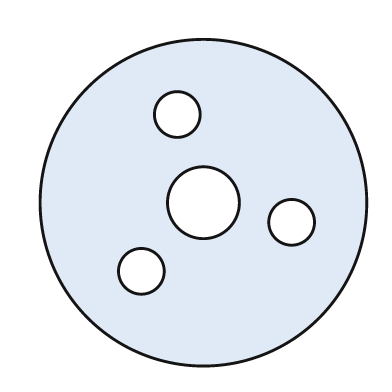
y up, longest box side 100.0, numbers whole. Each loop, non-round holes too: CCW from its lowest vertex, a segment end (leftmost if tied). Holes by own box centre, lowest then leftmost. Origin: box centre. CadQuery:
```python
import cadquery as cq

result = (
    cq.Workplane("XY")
    .moveTo(0.0, 0.0)
    .circle(50.0)
    .moveTo(-19.0, -21.0)
    .circle(7.0)
    .moveTo(27.0, -6.0)
    .circle(7.0)
    .moveTo(0.0, 0.0)
    .circle(11.0)
    .moveTo(-8.0, 27.0)
    .circle(7.0)
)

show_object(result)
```